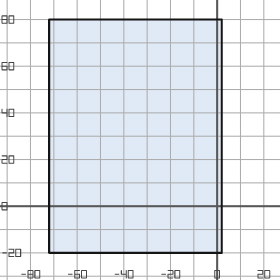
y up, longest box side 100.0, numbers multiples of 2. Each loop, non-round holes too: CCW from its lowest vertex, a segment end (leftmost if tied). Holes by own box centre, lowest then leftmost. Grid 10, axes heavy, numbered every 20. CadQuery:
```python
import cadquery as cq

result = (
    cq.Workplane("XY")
    .moveTo(-72.0, -20.0)
    .lineTo(2.0, -20.0)
    .lineTo(2.0, 80.0)
    .lineTo(-72.0, 80.0)
    .close()
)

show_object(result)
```